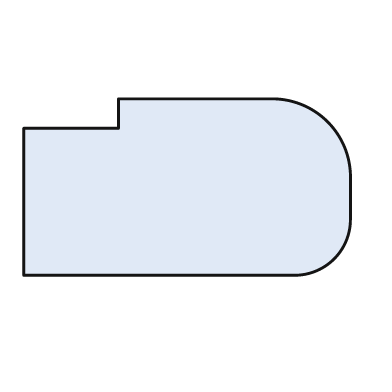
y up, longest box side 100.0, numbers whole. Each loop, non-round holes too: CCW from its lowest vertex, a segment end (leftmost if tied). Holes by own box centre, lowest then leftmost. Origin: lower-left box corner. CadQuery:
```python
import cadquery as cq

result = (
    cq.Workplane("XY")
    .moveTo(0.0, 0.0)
    .lineTo(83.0, 0.0)
    .threePointArc((95.0, 5.0), (100.0, 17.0))
    .lineTo(100.0, 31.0)
    .threePointArc((93.0, 47.0), (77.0, 54.0))
    .lineTo(29.0, 54.0)
    .lineTo(29.0, 45.0)
    .lineTo(0.0, 45.0)
    .close()
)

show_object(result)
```